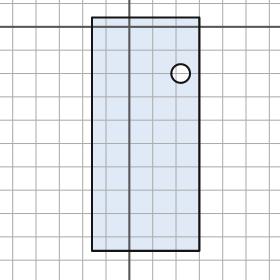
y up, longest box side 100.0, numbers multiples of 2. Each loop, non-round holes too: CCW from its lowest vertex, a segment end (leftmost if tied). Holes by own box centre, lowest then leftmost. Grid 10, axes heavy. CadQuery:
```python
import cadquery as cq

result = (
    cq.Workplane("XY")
    .moveTo(-16.0, -96.0)
    .lineTo(30.0, -96.0)
    .lineTo(30.0, 4.0)
    .lineTo(-16.0, 4.0)
    .close()
    .moveTo(22.0, -20.0)
    .circle(4.0)
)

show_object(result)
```